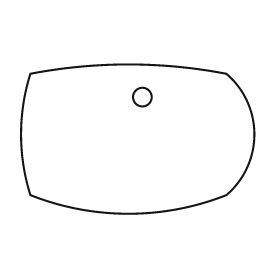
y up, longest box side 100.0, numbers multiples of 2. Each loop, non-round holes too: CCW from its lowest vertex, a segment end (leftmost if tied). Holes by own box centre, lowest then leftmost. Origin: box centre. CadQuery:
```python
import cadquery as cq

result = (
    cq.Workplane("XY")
    .moveTo(-46.0, -24.0)
    .threePointArc((-4.0, -32.0), (38.0, -24.0))
    .threePointArc((50.0, 2.0), (38.0, 28.0))
    .threePointArc((-4.0, 32.0), (-46.0, 28.0))
    .threePointArc((-50.0, 2.0), (-46.0, -24.0))
    .close()
    .moveTo(2.0, 18.0)
    .circle(4.0)
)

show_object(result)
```